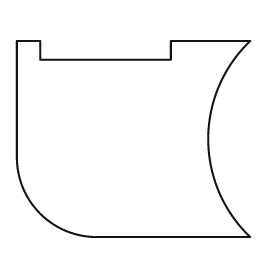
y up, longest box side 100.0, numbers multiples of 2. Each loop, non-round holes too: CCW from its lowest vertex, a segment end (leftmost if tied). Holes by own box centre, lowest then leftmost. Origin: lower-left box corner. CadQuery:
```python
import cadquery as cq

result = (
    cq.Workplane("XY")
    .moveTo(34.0, 0.0)
    .lineTo(100.0, 0.0)
    .threePointArc((82.0, 42.0), (100.0, 84.0))
    .lineTo(66.0, 84.0)
    .lineTo(66.0, 76.0)
    .lineTo(10.0, 76.0)
    .lineTo(10.0, 84.0)
    .lineTo(0.0, 84.0)
    .lineTo(0.0, 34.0)
    .threePointArc((10.0, 10.0), (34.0, 0.0))
    .close()
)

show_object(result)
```